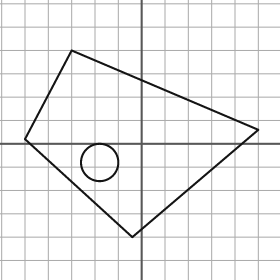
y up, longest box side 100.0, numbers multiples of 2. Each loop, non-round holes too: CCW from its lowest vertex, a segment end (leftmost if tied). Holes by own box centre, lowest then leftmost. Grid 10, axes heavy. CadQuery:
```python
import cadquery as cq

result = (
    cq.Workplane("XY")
    .moveTo(-4.0, -40.0)
    .lineTo(50.0, 6.0)
    .lineTo(-30.0, 40.0)
    .lineTo(-50.0, 2.0)
    .close()
    .moveTo(-18.0, -8.0)
    .circle(8.0)
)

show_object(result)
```